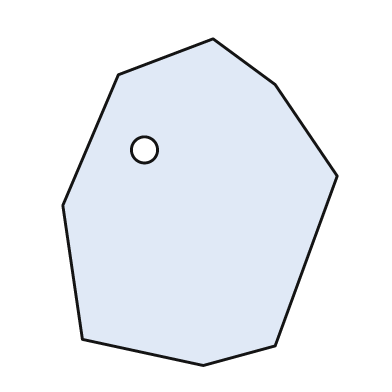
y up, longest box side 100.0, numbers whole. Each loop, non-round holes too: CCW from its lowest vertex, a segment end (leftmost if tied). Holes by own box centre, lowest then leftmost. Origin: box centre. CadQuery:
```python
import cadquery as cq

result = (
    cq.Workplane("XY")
    .moveTo(1.0, -50.0)
    .lineTo(23.0, -44.0)
    .lineTo(42.0, 8.0)
    .lineTo(23.0, 36.0)
    .lineTo(4.0, 50.0)
    .lineTo(-25.0, 39.0)
    .lineTo(-42.0, -1.0)
    .lineTo(-36.0, -42.0)
    .close()
    .moveTo(-17.0, 16.0)
    .circle(4.0)
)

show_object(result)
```